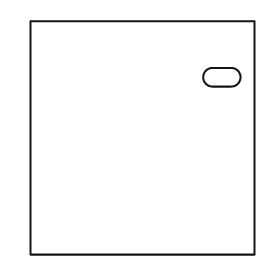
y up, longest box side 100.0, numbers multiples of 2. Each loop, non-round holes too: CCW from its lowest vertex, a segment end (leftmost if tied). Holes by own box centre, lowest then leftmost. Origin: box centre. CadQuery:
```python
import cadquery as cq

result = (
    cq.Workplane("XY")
    .moveTo(-48.0, -50.0)
    .lineTo(48.0, -50.0)
    .lineTo(48.0, 50.0)
    .lineTo(-48.0, 50.0)
    .close()
    .moveTo(30.0, 22.0)
    .lineTo(38.0, 22.0)
    .threePointArc((42.0, 26.0), (38.0, 30.0))
    .lineTo(30.0, 30.0)
    .threePointArc((26.0, 26.0), (30.0, 22.0))
    .close()
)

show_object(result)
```